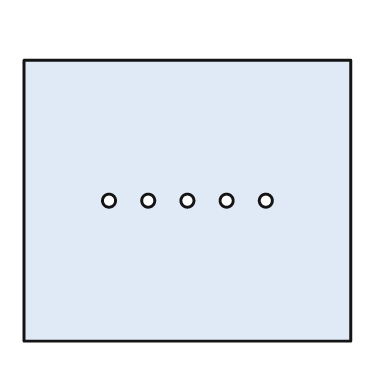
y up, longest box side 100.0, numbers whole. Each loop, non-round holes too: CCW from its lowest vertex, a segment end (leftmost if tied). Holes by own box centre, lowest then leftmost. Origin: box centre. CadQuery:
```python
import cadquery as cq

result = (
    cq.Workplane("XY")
    .moveTo(-50.0, -43.0)
    .lineTo(50.0, -43.0)
    .lineTo(50.0, 43.0)
    .lineTo(-50.0, 43.0)
    .close()
    .moveTo(-24.0, 0.0)
    .circle(2.0)
    .moveTo(-12.0, 0.0)
    .circle(2.0)
    .moveTo(0.0, 0.0)
    .circle(2.0)
    .moveTo(12.0, 0.0)
    .circle(2.0)
    .moveTo(24.0, 0.0)
    .circle(2.0)
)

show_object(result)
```